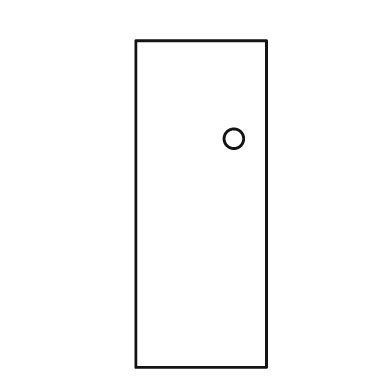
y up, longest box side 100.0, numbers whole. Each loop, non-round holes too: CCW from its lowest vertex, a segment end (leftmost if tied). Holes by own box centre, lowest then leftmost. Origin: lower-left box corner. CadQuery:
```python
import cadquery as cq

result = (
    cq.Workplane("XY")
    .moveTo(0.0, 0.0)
    .lineTo(40.0, 0.0)
    .lineTo(40.0, 100.0)
    .lineTo(0.0, 100.0)
    .close()
    .moveTo(30.0, 70.0)
    .circle(3.0)
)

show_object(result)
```